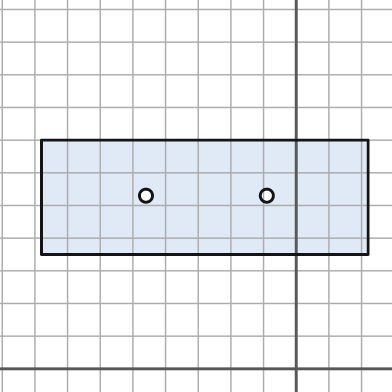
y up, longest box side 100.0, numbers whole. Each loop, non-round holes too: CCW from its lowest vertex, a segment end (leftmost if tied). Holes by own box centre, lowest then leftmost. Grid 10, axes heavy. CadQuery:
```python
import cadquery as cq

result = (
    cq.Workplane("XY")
    .moveTo(-78.0, 35.0)
    .lineTo(22.0, 35.0)
    .lineTo(22.0, 70.0)
    .lineTo(-78.0, 70.0)
    .close()
    .moveTo(-46.0, 53.0)
    .circle(2.0)
    .moveTo(-9.0, 53.0)
    .circle(2.0)
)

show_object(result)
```